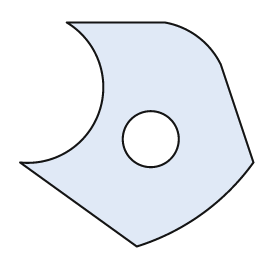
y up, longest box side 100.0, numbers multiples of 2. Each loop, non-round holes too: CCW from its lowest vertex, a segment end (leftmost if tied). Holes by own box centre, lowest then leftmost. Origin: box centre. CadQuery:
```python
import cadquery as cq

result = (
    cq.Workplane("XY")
    .moveTo(0.0, -48.0)
    .threePointArc((28.0, -34.0), (50.0, -12.0))
    .lineTo(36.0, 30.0)
    .threePointArc((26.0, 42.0), (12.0, 48.0))
    .lineTo(-30.0, 48.0)
    .threePointArc((-16.0, 10.0), (-50.0, -12.0))
    .close()
    .moveTo(6.0, -2.0)
    .circle(12.0)
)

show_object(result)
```